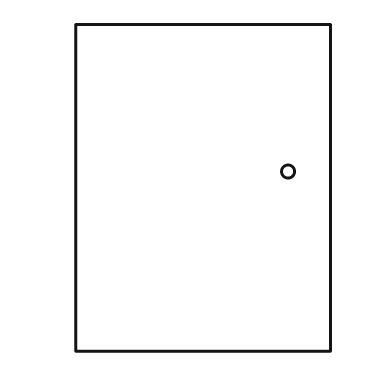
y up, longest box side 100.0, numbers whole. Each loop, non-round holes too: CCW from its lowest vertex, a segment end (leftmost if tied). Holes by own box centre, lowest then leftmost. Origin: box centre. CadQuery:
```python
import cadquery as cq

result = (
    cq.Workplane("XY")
    .moveTo(-39.0, -50.0)
    .lineTo(39.0, -50.0)
    .lineTo(39.0, 50.0)
    .lineTo(-39.0, 50.0)
    .close()
    .moveTo(26.0, 5.0)
    .circle(2.0)
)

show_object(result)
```